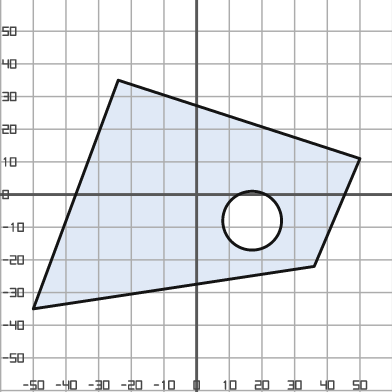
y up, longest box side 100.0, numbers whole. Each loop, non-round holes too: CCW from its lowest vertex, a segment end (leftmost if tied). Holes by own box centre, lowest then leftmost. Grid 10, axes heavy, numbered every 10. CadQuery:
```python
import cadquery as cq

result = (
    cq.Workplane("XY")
    .moveTo(-50.0, -35.0)
    .lineTo(36.0, -22.0)
    .lineTo(50.0, 11.0)
    .lineTo(-24.0, 35.0)
    .close()
    .moveTo(17.0, -8.0)
    .circle(9.0)
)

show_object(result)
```